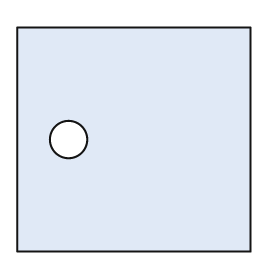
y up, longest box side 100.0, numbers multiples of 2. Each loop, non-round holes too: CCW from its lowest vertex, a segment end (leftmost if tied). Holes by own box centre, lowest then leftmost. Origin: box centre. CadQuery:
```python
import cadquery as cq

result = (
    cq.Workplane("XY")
    .moveTo(-50.0, -48.0)
    .lineTo(50.0, -48.0)
    .lineTo(50.0, 48.0)
    .lineTo(-50.0, 48.0)
    .close()
    .moveTo(-28.0, 0.0)
    .circle(8.0)
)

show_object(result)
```